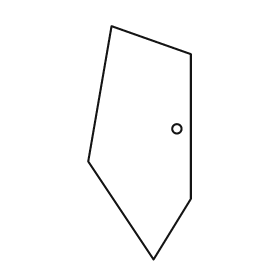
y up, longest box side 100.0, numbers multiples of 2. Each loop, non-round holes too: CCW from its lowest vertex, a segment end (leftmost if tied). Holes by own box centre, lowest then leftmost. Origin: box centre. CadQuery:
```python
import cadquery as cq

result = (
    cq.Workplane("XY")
    .moveTo(6.0, -50.0)
    .lineTo(22.0, -24.0)
    .lineTo(22.0, 38.0)
    .lineTo(-12.0, 50.0)
    .lineTo(-22.0, -8.0)
    .close()
    .moveTo(16.0, 6.0)
    .circle(2.0)
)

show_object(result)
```